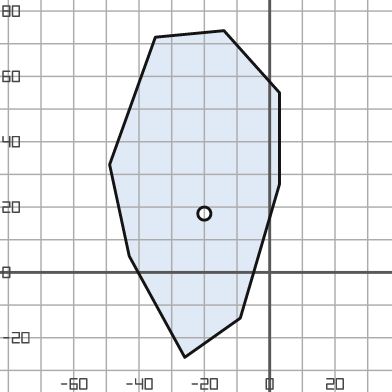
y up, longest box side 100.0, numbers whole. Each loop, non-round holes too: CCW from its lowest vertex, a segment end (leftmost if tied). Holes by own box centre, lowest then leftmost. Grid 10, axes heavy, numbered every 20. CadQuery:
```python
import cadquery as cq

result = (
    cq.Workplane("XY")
    .moveTo(-26.0, -26.0)
    .lineTo(-9.0, -14.0)
    .lineTo(3.0, 27.0)
    .lineTo(3.0, 55.0)
    .lineTo(-14.0, 74.0)
    .lineTo(-35.0, 72.0)
    .lineTo(-49.0, 33.0)
    .lineTo(-43.0, 5.0)
    .close()
    .moveTo(-20.0, 18.0)
    .circle(2.0)
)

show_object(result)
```